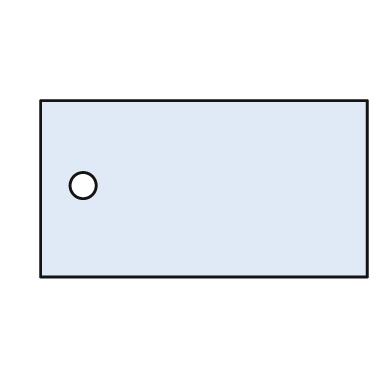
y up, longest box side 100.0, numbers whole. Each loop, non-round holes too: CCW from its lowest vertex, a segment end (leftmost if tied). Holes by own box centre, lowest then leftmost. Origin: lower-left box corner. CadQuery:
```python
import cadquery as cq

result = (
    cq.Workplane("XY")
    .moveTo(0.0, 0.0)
    .lineTo(100.0, 0.0)
    .lineTo(100.0, 54.0)
    .lineTo(0.0, 54.0)
    .close()
    .moveTo(13.0, 28.0)
    .circle(4.0)
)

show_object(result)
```